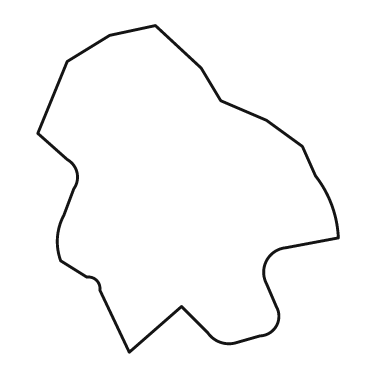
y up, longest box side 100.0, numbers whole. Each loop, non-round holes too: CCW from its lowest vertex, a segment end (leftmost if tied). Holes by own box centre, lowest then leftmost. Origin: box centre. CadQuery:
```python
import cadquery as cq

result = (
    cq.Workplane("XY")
    .moveTo(-18.0, -50.0)
    .lineTo(-2.0, -36.0)
    .lineTo(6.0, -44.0)
    .threePointArc((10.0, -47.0), (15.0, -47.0))
    .lineTo(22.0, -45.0)
    .threePointArc((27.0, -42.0), (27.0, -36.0))
    .lineTo(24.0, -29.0)
    .threePointArc((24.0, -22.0), (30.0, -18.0))
    .lineTo(46.0, -15.0)
    .threePointArc((44.0, -5.0), (39.0, 4.0))
    .lineTo(35.0, 13.0)
    .lineTo(24.0, 21.0)
    .lineTo(10.0, 27.0)
    .lineTo(4.0, 37.0)
    .lineTo(-10.0, 50.0)
    .lineTo(-24.0, 47.0)
    .lineTo(-37.0, 39.0)
    .lineTo(-46.0, 17.0)
    .lineTo(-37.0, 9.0)
    .threePointArc((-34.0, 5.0), (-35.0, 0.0))
    .lineTo(-38.0, -8.0)
    .threePointArc((-40.0, -15.0), (-39.0, -22.0))
    .lineTo(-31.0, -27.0)
    .threePointArc((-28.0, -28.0), (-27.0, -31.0))
    .close()
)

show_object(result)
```